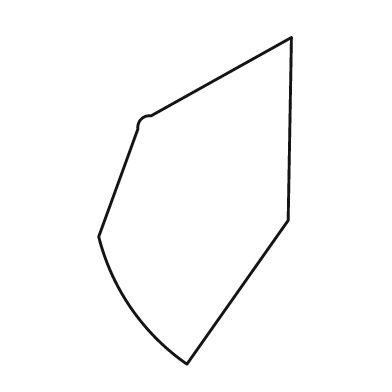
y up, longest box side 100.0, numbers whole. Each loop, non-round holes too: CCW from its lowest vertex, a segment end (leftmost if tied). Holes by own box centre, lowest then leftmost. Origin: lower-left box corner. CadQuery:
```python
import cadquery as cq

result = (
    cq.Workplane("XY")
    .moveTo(27.0, 0.0)
    .lineTo(58.0, 44.0)
    .lineTo(59.0, 100.0)
    .lineTo(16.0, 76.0)
    .threePointArc((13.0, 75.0), (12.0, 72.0))
    .lineTo(0.0, 39.0)
    .threePointArc((10.0, 17.0), (27.0, 0.0))
    .close()
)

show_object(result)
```